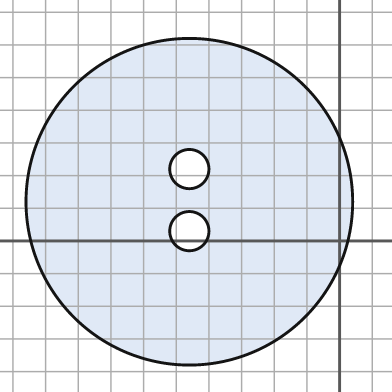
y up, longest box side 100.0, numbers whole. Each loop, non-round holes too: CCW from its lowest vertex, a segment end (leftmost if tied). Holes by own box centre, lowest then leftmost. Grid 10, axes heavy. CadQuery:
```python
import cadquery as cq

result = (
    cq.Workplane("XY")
    .moveTo(-46.0, 12.0)
    .circle(50.0)
    .moveTo(-46.0, 3.0)
    .circle(6.0)
    .moveTo(-46.0, 22.0)
    .circle(6.0)
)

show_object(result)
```